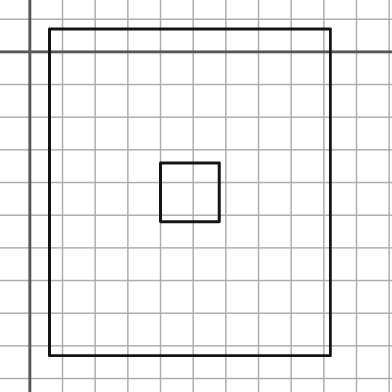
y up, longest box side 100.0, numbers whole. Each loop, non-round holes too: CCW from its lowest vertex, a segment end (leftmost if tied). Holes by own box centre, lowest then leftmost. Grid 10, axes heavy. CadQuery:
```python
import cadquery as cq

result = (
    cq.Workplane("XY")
    .moveTo(6.0, -93.0)
    .lineTo(92.0, -93.0)
    .lineTo(92.0, 7.0)
    .lineTo(6.0, 7.0)
    .close()
    .moveTo(40.0, -52.0)
    .lineTo(58.0, -52.0)
    .lineTo(58.0, -34.0)
    .lineTo(40.0, -34.0)
    .close()
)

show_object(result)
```